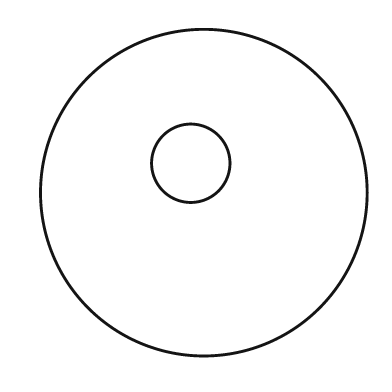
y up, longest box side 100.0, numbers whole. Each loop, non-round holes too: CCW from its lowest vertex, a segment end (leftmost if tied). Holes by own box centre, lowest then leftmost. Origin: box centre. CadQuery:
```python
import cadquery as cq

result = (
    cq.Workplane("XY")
    .moveTo(0.0, 0.0)
    .circle(50.0)
    .moveTo(-4.0, 9.0)
    .circle(12.0)
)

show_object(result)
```